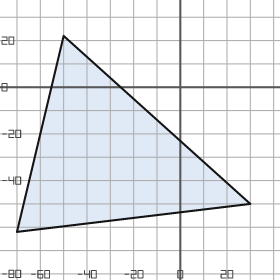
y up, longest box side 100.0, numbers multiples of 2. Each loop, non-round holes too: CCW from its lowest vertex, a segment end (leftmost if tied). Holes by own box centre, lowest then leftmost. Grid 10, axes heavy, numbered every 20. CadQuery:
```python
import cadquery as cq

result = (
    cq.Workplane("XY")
    .moveTo(-70.0, -62.0)
    .lineTo(30.0, -50.0)
    .lineTo(-50.0, 22.0)
    .close()
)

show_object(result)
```